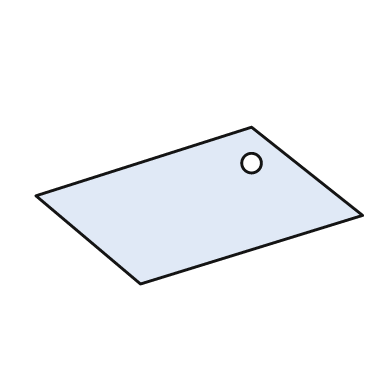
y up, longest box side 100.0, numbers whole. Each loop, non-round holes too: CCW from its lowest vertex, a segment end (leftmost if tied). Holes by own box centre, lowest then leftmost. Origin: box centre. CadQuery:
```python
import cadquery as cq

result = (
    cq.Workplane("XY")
    .moveTo(-18.0, -24.0)
    .lineTo(50.0, -3.0)
    .lineTo(16.0, 24.0)
    .lineTo(-50.0, 3.0)
    .close()
    .moveTo(16.0, 13.0)
    .circle(3.0)
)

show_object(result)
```